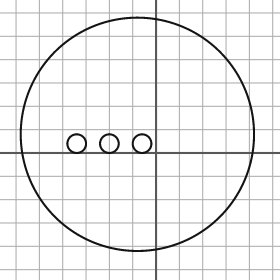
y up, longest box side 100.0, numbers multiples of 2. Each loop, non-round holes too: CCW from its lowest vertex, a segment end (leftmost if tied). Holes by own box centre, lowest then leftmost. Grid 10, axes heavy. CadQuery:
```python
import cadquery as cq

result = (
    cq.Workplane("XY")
    .moveTo(-8.0, 8.0)
    .circle(50.0)
    .moveTo(-34.0, 4.0)
    .circle(4.0)
    .moveTo(-20.0, 4.0)
    .circle(4.0)
    .moveTo(-6.0, 4.0)
    .circle(4.0)
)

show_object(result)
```